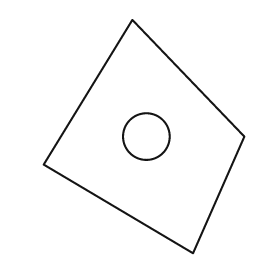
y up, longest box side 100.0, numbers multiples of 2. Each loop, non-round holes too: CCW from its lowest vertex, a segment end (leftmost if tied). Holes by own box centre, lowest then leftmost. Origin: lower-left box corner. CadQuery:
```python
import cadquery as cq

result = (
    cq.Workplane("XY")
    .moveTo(64.0, 0.0)
    .lineTo(86.0, 50.0)
    .lineTo(38.0, 100.0)
    .lineTo(0.0, 38.0)
    .close()
    .moveTo(44.0, 50.0)
    .circle(10.0)
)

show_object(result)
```